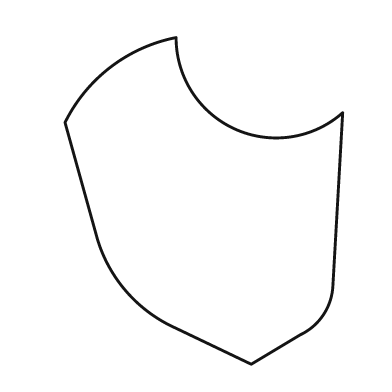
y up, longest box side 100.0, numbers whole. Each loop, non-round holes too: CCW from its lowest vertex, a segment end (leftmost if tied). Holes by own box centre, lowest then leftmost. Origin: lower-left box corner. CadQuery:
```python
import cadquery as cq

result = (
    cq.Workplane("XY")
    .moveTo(57.0, 0.0)
    .lineTo(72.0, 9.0)
    .threePointArc((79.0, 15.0), (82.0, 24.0))
    .lineTo(85.0, 77.0)
    .threePointArc((52.0, 72.0), (34.0, 100.0))
    .threePointArc((14.0, 91.0), (0.0, 74.0))
    .lineTo(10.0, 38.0)
    .threePointArc((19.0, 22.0), (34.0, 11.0))
    .close()
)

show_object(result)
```